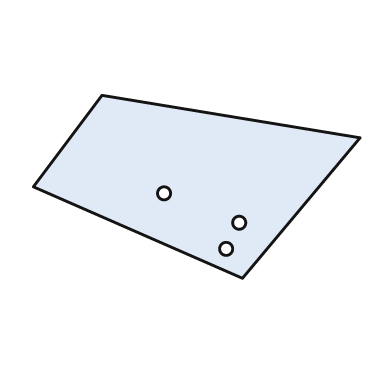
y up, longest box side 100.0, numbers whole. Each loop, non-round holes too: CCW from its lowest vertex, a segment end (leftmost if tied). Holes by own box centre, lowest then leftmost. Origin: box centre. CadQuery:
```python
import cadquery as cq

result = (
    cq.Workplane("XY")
    .moveTo(14.0, -28.0)
    .lineTo(50.0, 15.0)
    .lineTo(-29.0, 28.0)
    .lineTo(-50.0, 0.0)
    .close()
    .moveTo(9.0, -19.0)
    .circle(2.0)
    .moveTo(13.0, -11.0)
    .circle(2.0)
    .moveTo(-10.0, -2.0)
    .circle(2.0)
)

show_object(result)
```